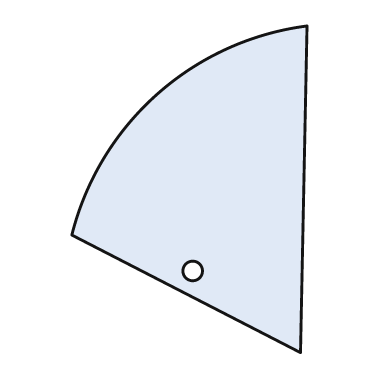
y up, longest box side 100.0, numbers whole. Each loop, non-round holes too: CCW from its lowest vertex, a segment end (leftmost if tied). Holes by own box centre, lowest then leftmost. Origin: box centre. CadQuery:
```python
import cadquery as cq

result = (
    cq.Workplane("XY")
    .moveTo(34.0, -50.0)
    .lineTo(36.0, 50.0)
    .threePointArc((-10.0, 29.0), (-36.0, -14.0))
    .close()
    .moveTo(1.0, -25.0)
    .circle(3.0)
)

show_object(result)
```